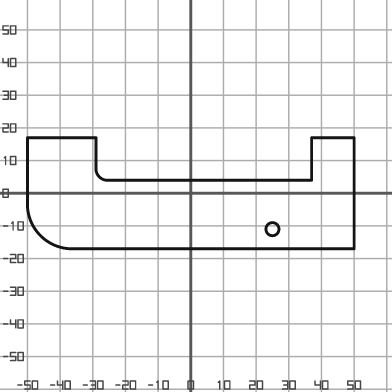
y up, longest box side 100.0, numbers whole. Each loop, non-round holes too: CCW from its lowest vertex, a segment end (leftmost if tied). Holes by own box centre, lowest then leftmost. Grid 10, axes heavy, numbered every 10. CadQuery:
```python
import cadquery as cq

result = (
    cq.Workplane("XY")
    .moveTo(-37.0, -17.0)
    .lineTo(50.0, -17.0)
    .lineTo(50.0, 17.0)
    .lineTo(37.0, 17.0)
    .lineTo(37.0, 4.0)
    .lineTo(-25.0, 4.0)
    .threePointArc((-28.0, 5.0), (-29.0, 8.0))
    .lineTo(-29.0, 17.0)
    .lineTo(-50.0, 17.0)
    .lineTo(-50.0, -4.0)
    .threePointArc((-46.0, -13.0), (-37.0, -17.0))
    .close()
    .moveTo(25.0, -11.0)
    .circle(2.0)
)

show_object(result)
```